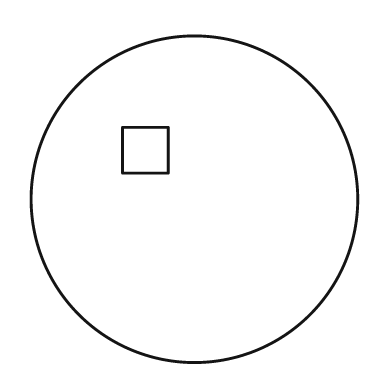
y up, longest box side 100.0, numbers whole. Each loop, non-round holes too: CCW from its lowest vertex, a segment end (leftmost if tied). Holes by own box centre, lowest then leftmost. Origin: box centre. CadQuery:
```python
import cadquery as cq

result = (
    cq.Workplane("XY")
    .moveTo(0.0, 0.0)
    .circle(50.0)
    .moveTo(-22.0, 8.0)
    .lineTo(-8.0, 8.0)
    .lineTo(-8.0, 22.0)
    .lineTo(-22.0, 22.0)
    .close()
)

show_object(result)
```